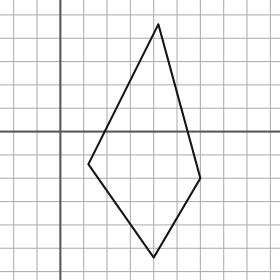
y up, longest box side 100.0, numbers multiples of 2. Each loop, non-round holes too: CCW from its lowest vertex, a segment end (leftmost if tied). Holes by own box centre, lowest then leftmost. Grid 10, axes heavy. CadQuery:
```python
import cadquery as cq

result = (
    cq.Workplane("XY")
    .moveTo(40.0, -54.0)
    .lineTo(60.0, -20.0)
    .lineTo(42.0, 46.0)
    .lineTo(12.0, -14.0)
    .close()
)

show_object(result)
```